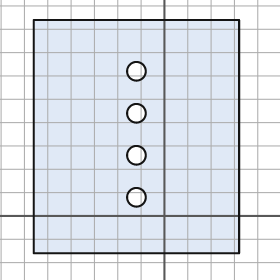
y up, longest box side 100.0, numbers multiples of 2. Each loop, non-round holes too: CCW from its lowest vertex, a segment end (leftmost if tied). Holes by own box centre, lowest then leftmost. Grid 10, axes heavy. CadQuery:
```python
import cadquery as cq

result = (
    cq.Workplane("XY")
    .moveTo(-56.0, -16.0)
    .lineTo(32.0, -16.0)
    .lineTo(32.0, 84.0)
    .lineTo(-56.0, 84.0)
    .close()
    .moveTo(-12.0, 8.0)
    .circle(4.0)
    .moveTo(-12.0, 26.0)
    .circle(4.0)
    .moveTo(-12.0, 44.0)
    .circle(4.0)
    .moveTo(-12.0, 62.0)
    .circle(4.0)
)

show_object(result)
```